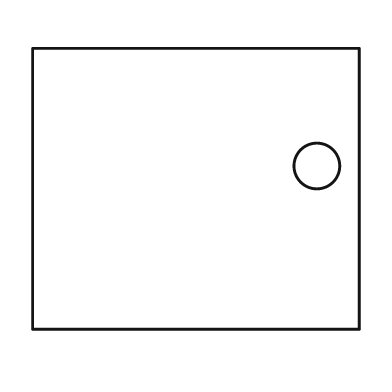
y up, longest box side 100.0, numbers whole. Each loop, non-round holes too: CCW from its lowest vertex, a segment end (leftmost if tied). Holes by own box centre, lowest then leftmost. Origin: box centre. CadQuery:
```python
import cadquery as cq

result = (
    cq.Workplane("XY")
    .moveTo(-50.0, -43.0)
    .lineTo(50.0, -43.0)
    .lineTo(50.0, 43.0)
    .lineTo(-50.0, 43.0)
    .close()
    .moveTo(37.0, 7.0)
    .circle(7.0)
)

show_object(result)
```